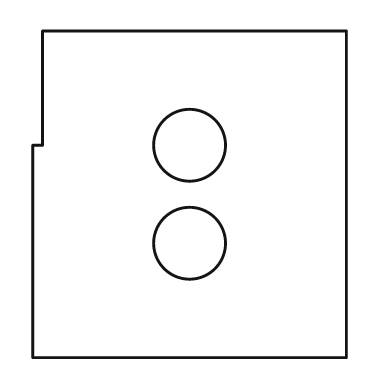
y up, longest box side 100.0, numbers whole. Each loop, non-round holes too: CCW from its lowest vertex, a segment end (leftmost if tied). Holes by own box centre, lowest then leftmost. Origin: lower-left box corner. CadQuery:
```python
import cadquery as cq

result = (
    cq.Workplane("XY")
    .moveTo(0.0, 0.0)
    .lineTo(96.0, 0.0)
    .lineTo(96.0, 100.0)
    .lineTo(3.0, 100.0)
    .lineTo(3.0, 65.0)
    .lineTo(0.0, 65.0)
    .close()
    .moveTo(48.0, 35.0)
    .circle(11.0)
    .moveTo(48.0, 65.0)
    .circle(11.0)
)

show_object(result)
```